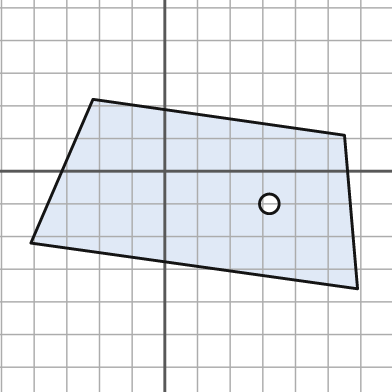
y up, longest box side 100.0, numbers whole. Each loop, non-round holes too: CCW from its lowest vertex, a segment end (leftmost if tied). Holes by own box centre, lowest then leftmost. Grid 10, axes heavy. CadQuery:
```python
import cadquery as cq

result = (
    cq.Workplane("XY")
    .moveTo(59.0, -36.0)
    .lineTo(55.0, 11.0)
    .lineTo(-22.0, 22.0)
    .lineTo(-41.0, -22.0)
    .close()
    .moveTo(32.0, -10.0)
    .circle(3.0)
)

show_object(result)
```